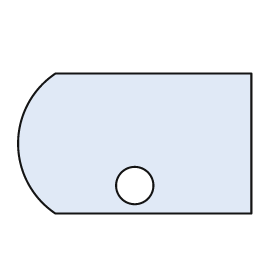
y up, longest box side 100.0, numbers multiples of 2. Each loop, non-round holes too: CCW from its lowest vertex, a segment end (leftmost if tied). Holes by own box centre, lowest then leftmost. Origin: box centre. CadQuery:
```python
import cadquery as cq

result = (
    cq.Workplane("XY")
    .moveTo(-34.0, -30.0)
    .lineTo(50.0, -30.0)
    .lineTo(50.0, 30.0)
    .lineTo(-34.0, 30.0)
    .threePointArc((-50.0, 0.0), (-34.0, -30.0))
    .close()
    .moveTo(0.0, -18.0)
    .circle(8.0)
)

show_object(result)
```